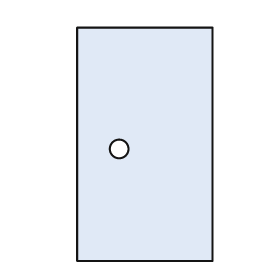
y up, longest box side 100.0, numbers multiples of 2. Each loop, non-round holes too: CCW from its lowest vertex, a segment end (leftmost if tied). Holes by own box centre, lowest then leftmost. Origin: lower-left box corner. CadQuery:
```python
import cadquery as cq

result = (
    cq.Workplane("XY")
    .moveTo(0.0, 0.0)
    .lineTo(58.0, 0.0)
    .lineTo(58.0, 100.0)
    .lineTo(0.0, 100.0)
    .close()
    .moveTo(18.0, 48.0)
    .circle(4.0)
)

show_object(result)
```